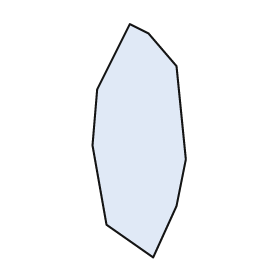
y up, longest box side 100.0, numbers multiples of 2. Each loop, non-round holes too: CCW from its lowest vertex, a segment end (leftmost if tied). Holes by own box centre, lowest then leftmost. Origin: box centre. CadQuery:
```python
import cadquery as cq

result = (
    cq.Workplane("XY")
    .moveTo(6.0, -50.0)
    .lineTo(16.0, -28.0)
    .lineTo(20.0, -8.0)
    .lineTo(16.0, 32.0)
    .lineTo(4.0, 46.0)
    .lineTo(-4.0, 50.0)
    .lineTo(-18.0, 22.0)
    .lineTo(-20.0, -2.0)
    .lineTo(-14.0, -36.0)
    .close()
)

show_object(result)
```